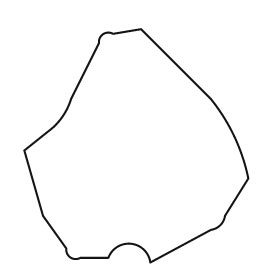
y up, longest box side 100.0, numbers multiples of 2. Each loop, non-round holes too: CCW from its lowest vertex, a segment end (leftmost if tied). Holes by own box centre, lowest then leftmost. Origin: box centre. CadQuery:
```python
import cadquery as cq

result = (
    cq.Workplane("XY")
    .moveTo(6.0, -50.0)
    .lineTo(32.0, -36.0)
    .threePointArc((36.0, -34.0), (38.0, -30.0))
    .lineTo(48.0, -14.0)
    .threePointArc((42.0, 4.0), (32.0, 20.0))
    .lineTo(2.0, 50.0)
    .lineTo(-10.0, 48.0)
    .threePointArc((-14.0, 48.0), (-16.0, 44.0))
    .lineTo(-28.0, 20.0)
    .threePointArc((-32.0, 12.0), (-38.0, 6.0))
    .lineTo(-48.0, -2.0)
    .lineTo(-40.0, -30.0)
    .lineTo(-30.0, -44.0)
    .threePointArc((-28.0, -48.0), (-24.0, -48.0))
    .lineTo(-12.0, -48.0)
    .threePointArc((-2.0, -42.0), (6.0, -50.0))
    .close()
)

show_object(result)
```